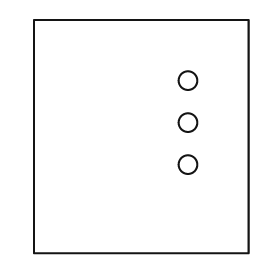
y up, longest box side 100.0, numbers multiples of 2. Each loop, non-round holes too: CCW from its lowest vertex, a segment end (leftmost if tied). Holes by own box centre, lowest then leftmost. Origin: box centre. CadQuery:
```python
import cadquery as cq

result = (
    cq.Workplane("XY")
    .moveTo(-46.0, -50.0)
    .lineTo(46.0, -50.0)
    .lineTo(46.0, 50.0)
    .lineTo(-46.0, 50.0)
    .close()
    .moveTo(20.0, -12.0)
    .circle(4.0)
    .moveTo(20.0, 6.0)
    .circle(4.0)
    .moveTo(20.0, 24.0)
    .circle(4.0)
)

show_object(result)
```